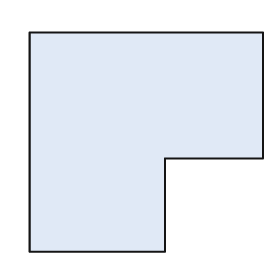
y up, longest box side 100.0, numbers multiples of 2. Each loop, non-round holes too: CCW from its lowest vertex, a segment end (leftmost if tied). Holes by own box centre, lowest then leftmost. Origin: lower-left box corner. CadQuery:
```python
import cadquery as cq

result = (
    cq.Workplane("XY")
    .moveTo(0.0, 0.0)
    .lineTo(58.0, 0.0)
    .lineTo(58.0, 40.0)
    .lineTo(100.0, 40.0)
    .lineTo(100.0, 94.0)
    .lineTo(0.0, 94.0)
    .close()
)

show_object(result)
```